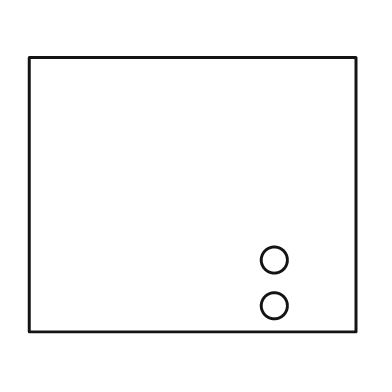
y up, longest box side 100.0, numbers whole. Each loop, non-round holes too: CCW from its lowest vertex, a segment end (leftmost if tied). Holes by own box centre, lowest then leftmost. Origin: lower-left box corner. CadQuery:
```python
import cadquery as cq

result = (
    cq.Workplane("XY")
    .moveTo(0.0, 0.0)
    .lineTo(100.0, 0.0)
    .lineTo(100.0, 84.0)
    .lineTo(0.0, 84.0)
    .close()
    .moveTo(75.0, 8.0)
    .circle(4.0)
    .moveTo(75.0, 22.0)
    .circle(4.0)
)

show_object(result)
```